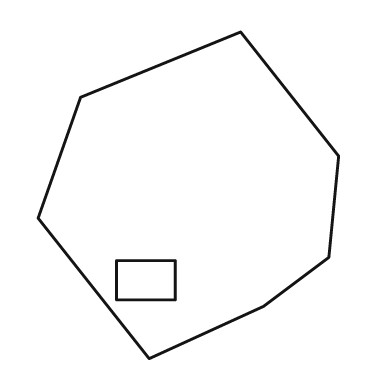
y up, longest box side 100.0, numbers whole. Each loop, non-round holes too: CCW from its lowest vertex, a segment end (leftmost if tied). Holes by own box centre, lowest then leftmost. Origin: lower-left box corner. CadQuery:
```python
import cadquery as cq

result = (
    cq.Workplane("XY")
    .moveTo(34.0, 0.0)
    .lineTo(69.0, 16.0)
    .lineTo(89.0, 31.0)
    .lineTo(92.0, 62.0)
    .lineTo(62.0, 100.0)
    .lineTo(13.0, 80.0)
    .lineTo(0.0, 43.0)
    .close()
    .moveTo(24.0, 18.0)
    .lineTo(42.0, 18.0)
    .lineTo(42.0, 30.0)
    .lineTo(24.0, 30.0)
    .close()
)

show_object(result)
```